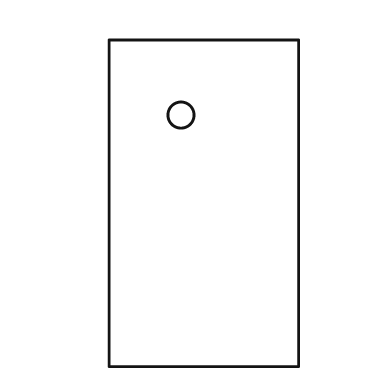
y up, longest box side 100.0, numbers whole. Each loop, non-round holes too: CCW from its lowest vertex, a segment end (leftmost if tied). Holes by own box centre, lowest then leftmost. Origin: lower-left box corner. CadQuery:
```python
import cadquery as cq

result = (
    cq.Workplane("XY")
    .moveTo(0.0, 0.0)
    .lineTo(58.0, 0.0)
    .lineTo(58.0, 100.0)
    .lineTo(0.0, 100.0)
    .close()
    .moveTo(22.0, 77.0)
    .circle(4.0)
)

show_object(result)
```